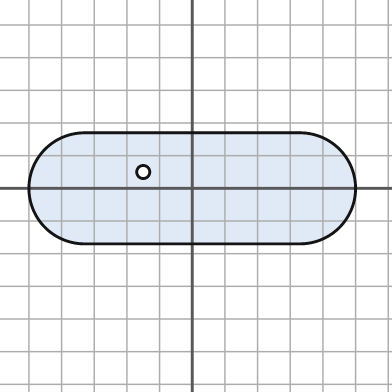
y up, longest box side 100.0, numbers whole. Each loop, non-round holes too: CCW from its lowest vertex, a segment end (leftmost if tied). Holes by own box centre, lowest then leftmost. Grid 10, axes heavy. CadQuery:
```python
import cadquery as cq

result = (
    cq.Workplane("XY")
    .moveTo(-33.0, -17.0)
    .lineTo(33.0, -17.0)
    .threePointArc((50.0, 0.0), (33.0, 17.0))
    .lineTo(-33.0, 17.0)
    .threePointArc((-50.0, 0.0), (-33.0, -17.0))
    .close()
    .moveTo(-15.0, 5.0)
    .circle(2.0)
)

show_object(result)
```